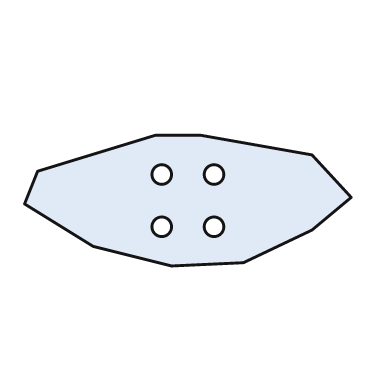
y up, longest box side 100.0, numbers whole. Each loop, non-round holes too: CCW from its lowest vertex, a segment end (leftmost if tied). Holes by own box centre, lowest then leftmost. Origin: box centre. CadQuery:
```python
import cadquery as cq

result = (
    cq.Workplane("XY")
    .moveTo(-5.0, -20.0)
    .lineTo(17.0, -19.0)
    .lineTo(38.0, -9.0)
    .lineTo(50.0, 1.0)
    .lineTo(38.0, 14.0)
    .lineTo(4.0, 20.0)
    .lineTo(-10.0, 20.0)
    .lineTo(-46.0, 9.0)
    .lineTo(-50.0, -1.0)
    .lineTo(-29.0, -14.0)
    .close()
    .moveTo(-8.0, -8.0)
    .circle(3.0)
    .moveTo(8.0, -8.0)
    .circle(3.0)
    .moveTo(-8.0, 8.0)
    .circle(3.0)
    .moveTo(8.0, 8.0)
    .circle(3.0)
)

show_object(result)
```